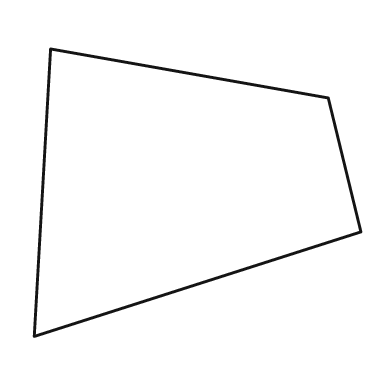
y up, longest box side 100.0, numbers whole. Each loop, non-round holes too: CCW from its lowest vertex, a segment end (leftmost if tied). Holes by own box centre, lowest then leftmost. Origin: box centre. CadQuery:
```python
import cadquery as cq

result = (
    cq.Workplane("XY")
    .moveTo(-50.0, -44.0)
    .lineTo(50.0, -12.0)
    .lineTo(40.0, 29.0)
    .lineTo(-45.0, 44.0)
    .close()
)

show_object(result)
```